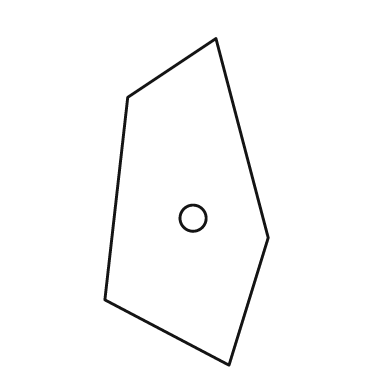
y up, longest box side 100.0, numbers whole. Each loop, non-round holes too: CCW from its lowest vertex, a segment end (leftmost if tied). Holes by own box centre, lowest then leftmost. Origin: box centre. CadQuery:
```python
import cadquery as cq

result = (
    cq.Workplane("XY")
    .moveTo(13.0, -50.0)
    .lineTo(25.0, -11.0)
    .lineTo(9.0, 50.0)
    .lineTo(-18.0, 32.0)
    .lineTo(-25.0, -30.0)
    .close()
    .moveTo(2.0, -5.0)
    .circle(4.0)
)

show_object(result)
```